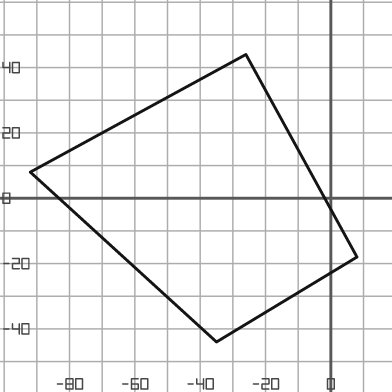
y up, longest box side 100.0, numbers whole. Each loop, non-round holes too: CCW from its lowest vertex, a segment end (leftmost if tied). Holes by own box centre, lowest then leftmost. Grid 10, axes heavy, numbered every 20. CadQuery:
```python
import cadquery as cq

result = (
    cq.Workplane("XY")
    .moveTo(-35.0, -44.0)
    .lineTo(8.0, -18.0)
    .lineTo(-26.0, 44.0)
    .lineTo(-92.0, 8.0)
    .close()
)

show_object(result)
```